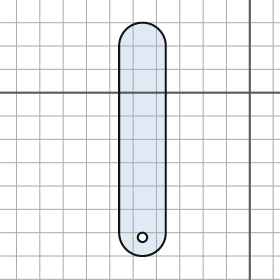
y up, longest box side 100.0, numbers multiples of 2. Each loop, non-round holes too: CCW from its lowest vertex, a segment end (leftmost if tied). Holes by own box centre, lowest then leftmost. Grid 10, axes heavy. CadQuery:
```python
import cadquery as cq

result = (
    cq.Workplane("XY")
    .moveTo(-56.0, -60.0)
    .threePointArc((-46.0, -70.0), (-36.0, -60.0))
    .lineTo(-36.0, 20.0)
    .threePointArc((-46.0, 30.0), (-56.0, 20.0))
    .close()
    .moveTo(-46.0, -62.0)
    .circle(2.0)
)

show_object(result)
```